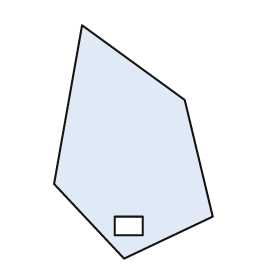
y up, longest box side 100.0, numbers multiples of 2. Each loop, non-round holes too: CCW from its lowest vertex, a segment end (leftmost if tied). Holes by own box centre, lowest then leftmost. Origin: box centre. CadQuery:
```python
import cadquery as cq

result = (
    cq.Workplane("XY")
    .moveTo(-4.0, -50.0)
    .lineTo(34.0, -32.0)
    .lineTo(22.0, 18.0)
    .lineTo(-22.0, 50.0)
    .lineTo(-34.0, -18.0)
    .close()
    .moveTo(-8.0, -40.0)
    .lineTo(4.0, -40.0)
    .lineTo(4.0, -32.0)
    .lineTo(-8.0, -32.0)
    .close()
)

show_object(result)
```